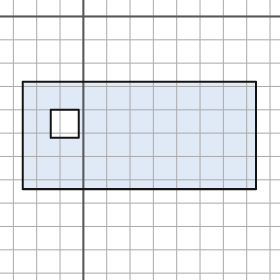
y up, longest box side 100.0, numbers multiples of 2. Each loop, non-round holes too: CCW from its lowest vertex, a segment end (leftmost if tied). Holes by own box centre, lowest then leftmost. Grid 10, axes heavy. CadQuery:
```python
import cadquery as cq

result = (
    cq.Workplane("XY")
    .moveTo(-26.0, -74.0)
    .lineTo(74.0, -74.0)
    .lineTo(74.0, -28.0)
    .lineTo(-26.0, -28.0)
    .close()
    .moveTo(-14.0, -52.0)
    .lineTo(-2.0, -52.0)
    .lineTo(-2.0, -40.0)
    .lineTo(-14.0, -40.0)
    .close()
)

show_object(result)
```